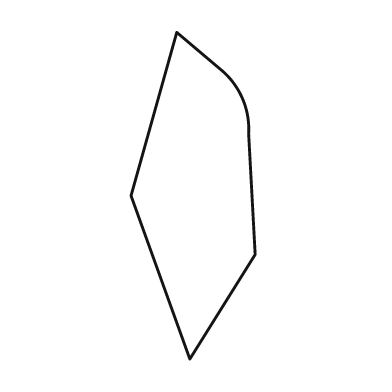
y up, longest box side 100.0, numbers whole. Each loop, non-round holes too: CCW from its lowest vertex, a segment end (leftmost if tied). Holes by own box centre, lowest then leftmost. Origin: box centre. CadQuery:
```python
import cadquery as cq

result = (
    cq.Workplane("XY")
    .moveTo(-1.0, -50.0)
    .lineTo(19.0, -18.0)
    .lineTo(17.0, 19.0)
    .threePointArc((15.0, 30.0), (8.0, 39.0))
    .lineTo(-5.0, 50.0)
    .lineTo(-19.0, 0.0)
    .close()
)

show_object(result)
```